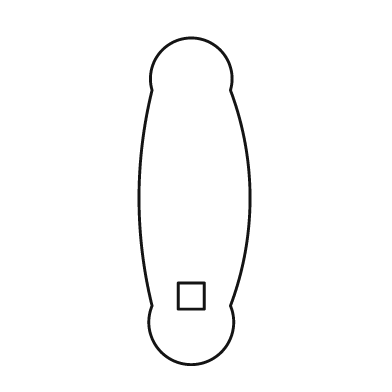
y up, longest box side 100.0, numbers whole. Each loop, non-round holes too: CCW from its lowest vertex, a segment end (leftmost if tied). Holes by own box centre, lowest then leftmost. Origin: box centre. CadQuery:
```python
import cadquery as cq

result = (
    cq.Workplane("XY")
    .moveTo(-13.0, -32.0)
    .threePointArc((-1.0, -50.0), (11.0, -32.0))
    .threePointArc((17.0, 1.0), (11.0, 34.0))
    .threePointArc((-1.0, 50.0), (-13.0, 34.0))
    .threePointArc((-17.0, 1.0), (-13.0, -32.0))
    .close()
    .moveTo(-5.0, -33.0)
    .lineTo(3.0, -33.0)
    .lineTo(3.0, -25.0)
    .lineTo(-5.0, -25.0)
    .close()
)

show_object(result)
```